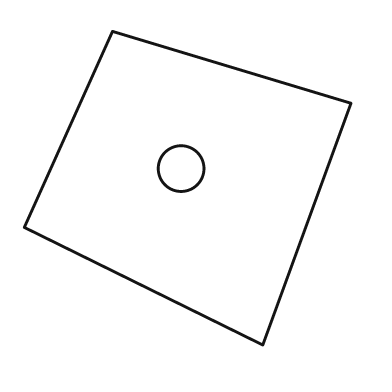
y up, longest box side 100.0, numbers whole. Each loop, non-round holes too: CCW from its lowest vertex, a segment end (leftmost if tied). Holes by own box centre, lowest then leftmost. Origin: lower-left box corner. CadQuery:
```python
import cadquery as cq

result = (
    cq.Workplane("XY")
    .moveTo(73.0, 0.0)
    .lineTo(100.0, 74.0)
    .lineTo(27.0, 96.0)
    .lineTo(0.0, 36.0)
    .close()
    .moveTo(48.0, 54.0)
    .circle(7.0)
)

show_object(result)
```